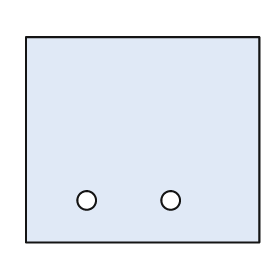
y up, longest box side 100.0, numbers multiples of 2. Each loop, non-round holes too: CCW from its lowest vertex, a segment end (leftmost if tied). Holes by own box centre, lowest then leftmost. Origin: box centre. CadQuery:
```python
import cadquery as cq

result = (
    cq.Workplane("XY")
    .moveTo(-50.0, -44.0)
    .lineTo(50.0, -44.0)
    .lineTo(50.0, 44.0)
    .lineTo(-50.0, 44.0)
    .close()
    .moveTo(-24.0, -26.0)
    .circle(4.0)
    .moveTo(12.0, -26.0)
    .circle(4.0)
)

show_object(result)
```